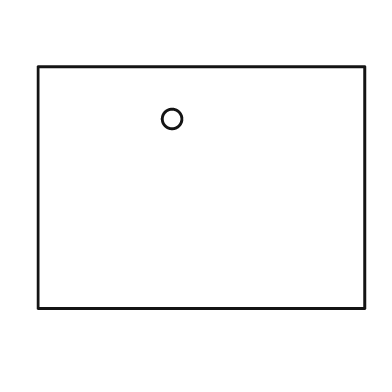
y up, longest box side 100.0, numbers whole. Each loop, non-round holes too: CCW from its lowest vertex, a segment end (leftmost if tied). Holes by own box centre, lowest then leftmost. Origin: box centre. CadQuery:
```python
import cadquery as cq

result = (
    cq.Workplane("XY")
    .moveTo(-50.0, -37.0)
    .lineTo(50.0, -37.0)
    .lineTo(50.0, 37.0)
    .lineTo(-50.0, 37.0)
    .close()
    .moveTo(-9.0, 21.0)
    .circle(3.0)
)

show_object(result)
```